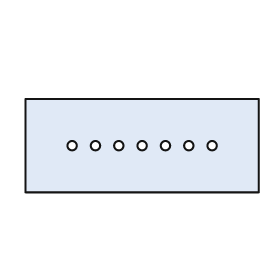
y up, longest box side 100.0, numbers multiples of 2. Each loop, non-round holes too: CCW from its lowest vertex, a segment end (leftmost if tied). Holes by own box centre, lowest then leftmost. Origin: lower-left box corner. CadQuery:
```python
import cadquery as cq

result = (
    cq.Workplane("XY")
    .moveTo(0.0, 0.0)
    .lineTo(100.0, 0.0)
    .lineTo(100.0, 40.0)
    .lineTo(0.0, 40.0)
    .close()
    .moveTo(20.0, 20.0)
    .circle(2.0)
    .moveTo(30.0, 20.0)
    .circle(2.0)
    .moveTo(40.0, 20.0)
    .circle(2.0)
    .moveTo(50.0, 20.0)
    .circle(2.0)
    .moveTo(60.0, 20.0)
    .circle(2.0)
    .moveTo(70.0, 20.0)
    .circle(2.0)
    .moveTo(80.0, 20.0)
    .circle(2.0)
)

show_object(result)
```